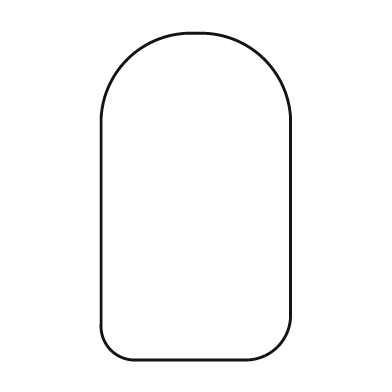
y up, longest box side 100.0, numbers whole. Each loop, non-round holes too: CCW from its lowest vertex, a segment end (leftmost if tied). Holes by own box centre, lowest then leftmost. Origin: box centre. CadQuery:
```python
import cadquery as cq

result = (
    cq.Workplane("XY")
    .moveTo(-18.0, -50.0)
    .lineTo(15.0, -50.0)
    .threePointArc((25.0, -46.0), (29.0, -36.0))
    .lineTo(29.0, 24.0)
    .threePointArc((21.0, 42.0), (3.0, 50.0))
    .lineTo(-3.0, 50.0)
    .threePointArc((-21.0, 42.0), (-29.0, 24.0))
    .lineTo(-29.0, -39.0)
    .threePointArc((-26.0, -47.0), (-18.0, -50.0))
    .close()
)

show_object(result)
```